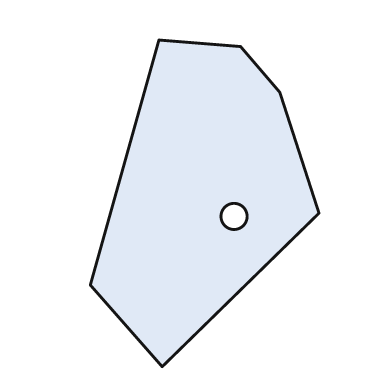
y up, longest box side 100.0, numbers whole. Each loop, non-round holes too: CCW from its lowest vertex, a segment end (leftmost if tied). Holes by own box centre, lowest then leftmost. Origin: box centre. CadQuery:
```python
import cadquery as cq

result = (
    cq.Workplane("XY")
    .moveTo(-13.0, -50.0)
    .lineTo(35.0, -3.0)
    .lineTo(23.0, 34.0)
    .lineTo(11.0, 48.0)
    .lineTo(-14.0, 50.0)
    .lineTo(-35.0, -25.0)
    .close()
    .moveTo(9.0, -4.0)
    .circle(4.0)
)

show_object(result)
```